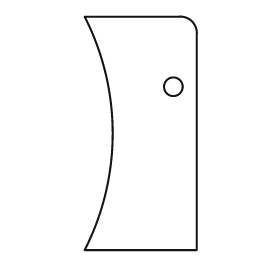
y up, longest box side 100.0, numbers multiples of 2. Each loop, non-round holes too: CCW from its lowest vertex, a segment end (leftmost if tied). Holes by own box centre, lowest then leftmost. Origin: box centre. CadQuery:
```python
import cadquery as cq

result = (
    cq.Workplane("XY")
    .moveTo(-24.0, -50.0)
    .lineTo(24.0, -50.0)
    .lineTo(24.0, 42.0)
    .threePointArc((22.0, 48.0), (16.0, 50.0))
    .lineTo(-24.0, 50.0)
    .threePointArc((-12.0, 0.0), (-24.0, -50.0))
    .close()
    .moveTo(14.0, 20.0)
    .circle(4.0)
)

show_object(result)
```